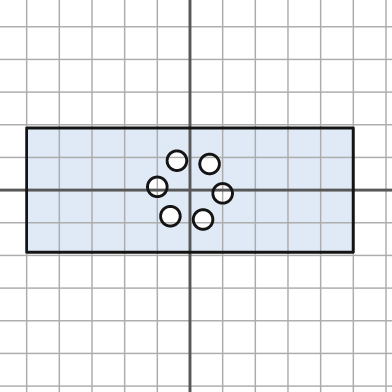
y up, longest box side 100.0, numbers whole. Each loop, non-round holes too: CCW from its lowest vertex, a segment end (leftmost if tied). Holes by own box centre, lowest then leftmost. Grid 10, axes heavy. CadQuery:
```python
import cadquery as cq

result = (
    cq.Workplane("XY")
    .moveTo(-50.0, -19.0)
    .lineTo(50.0, -19.0)
    .lineTo(50.0, 19.0)
    .lineTo(-50.0, 19.0)
    .close()
    .moveTo(4.0, -9.0)
    .circle(3.0)
    .moveTo(-6.0, -8.0)
    .circle(3.0)
    .moveTo(10.0, -1.0)
    .circle(3.0)
    .moveTo(-10.0, 1.0)
    .circle(3.0)
    .moveTo(6.0, 8.0)
    .circle(3.0)
    .moveTo(-4.0, 9.0)
    .circle(3.0)
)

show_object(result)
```